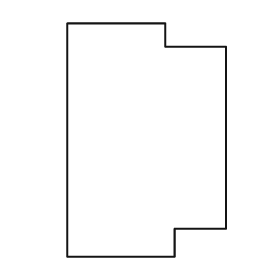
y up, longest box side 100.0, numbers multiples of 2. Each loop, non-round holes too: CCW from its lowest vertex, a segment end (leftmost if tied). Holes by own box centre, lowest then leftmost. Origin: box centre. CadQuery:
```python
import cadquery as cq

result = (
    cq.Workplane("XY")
    .moveTo(-34.0, -50.0)
    .lineTo(12.0, -50.0)
    .lineTo(12.0, -38.0)
    .lineTo(34.0, -38.0)
    .lineTo(34.0, 40.0)
    .lineTo(8.0, 40.0)
    .lineTo(8.0, 50.0)
    .lineTo(-34.0, 50.0)
    .close()
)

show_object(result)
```